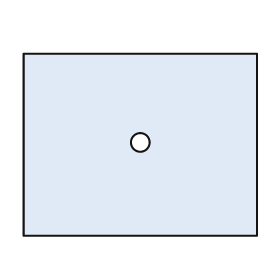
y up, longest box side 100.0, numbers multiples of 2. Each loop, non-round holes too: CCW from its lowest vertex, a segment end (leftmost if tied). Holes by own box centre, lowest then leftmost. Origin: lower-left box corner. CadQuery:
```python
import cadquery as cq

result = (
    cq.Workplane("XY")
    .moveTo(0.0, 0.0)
    .lineTo(100.0, 0.0)
    .lineTo(100.0, 78.0)
    .lineTo(0.0, 78.0)
    .close()
    .moveTo(50.0, 40.0)
    .circle(4.0)
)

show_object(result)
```